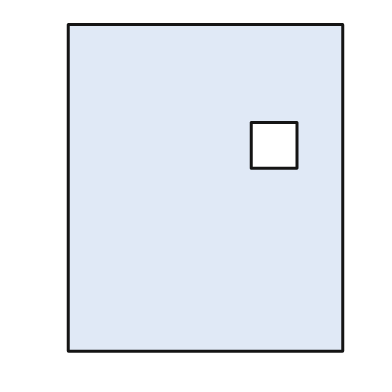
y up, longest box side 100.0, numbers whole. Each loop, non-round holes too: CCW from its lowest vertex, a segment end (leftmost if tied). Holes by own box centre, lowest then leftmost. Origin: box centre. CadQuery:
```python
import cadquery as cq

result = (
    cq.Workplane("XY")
    .moveTo(-42.0, -50.0)
    .lineTo(42.0, -50.0)
    .lineTo(42.0, 50.0)
    .lineTo(-42.0, 50.0)
    .close()
    .moveTo(14.0, 6.0)
    .lineTo(28.0, 6.0)
    .lineTo(28.0, 20.0)
    .lineTo(14.0, 20.0)
    .close()
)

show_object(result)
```